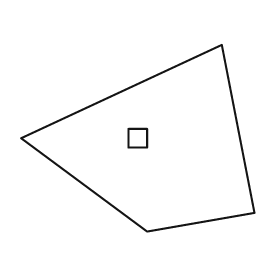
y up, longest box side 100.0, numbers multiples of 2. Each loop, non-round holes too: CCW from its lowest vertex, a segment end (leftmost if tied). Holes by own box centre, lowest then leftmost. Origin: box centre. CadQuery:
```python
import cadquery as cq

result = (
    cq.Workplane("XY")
    .moveTo(4.0, -40.0)
    .lineTo(50.0, -32.0)
    .lineTo(36.0, 40.0)
    .lineTo(-50.0, 0.0)
    .close()
    .moveTo(-4.0, -4.0)
    .lineTo(4.0, -4.0)
    .lineTo(4.0, 4.0)
    .lineTo(-4.0, 4.0)
    .close()
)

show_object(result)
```